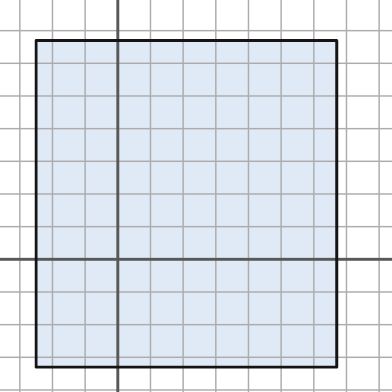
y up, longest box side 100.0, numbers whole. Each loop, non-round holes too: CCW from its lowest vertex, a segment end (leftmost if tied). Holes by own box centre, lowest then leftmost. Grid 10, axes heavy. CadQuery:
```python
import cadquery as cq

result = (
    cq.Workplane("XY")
    .moveTo(-25.0, -33.0)
    .lineTo(67.0, -33.0)
    .lineTo(67.0, 67.0)
    .lineTo(-25.0, 67.0)
    .close()
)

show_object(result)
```